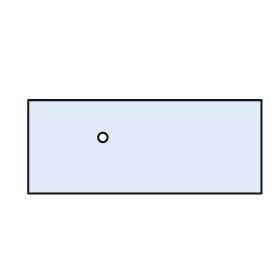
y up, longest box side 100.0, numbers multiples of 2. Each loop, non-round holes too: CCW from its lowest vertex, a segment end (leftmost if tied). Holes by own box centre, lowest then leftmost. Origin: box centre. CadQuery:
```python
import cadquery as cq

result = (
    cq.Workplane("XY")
    .moveTo(-50.0, -20.0)
    .lineTo(50.0, -20.0)
    .lineTo(50.0, 20.0)
    .lineTo(-50.0, 20.0)
    .close()
    .moveTo(-18.0, 4.0)
    .circle(2.0)
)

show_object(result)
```